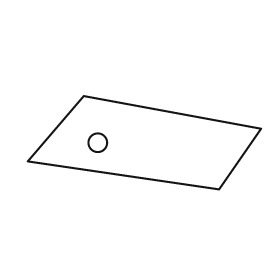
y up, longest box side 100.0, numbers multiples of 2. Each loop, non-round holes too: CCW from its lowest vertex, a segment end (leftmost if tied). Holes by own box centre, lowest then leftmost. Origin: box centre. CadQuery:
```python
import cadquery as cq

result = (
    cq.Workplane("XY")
    .moveTo(32.0, -20.0)
    .lineTo(50.0, 6.0)
    .lineTo(-26.0, 20.0)
    .lineTo(-50.0, -8.0)
    .close()
    .moveTo(-20.0, 0.0)
    .circle(4.0)
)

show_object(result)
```